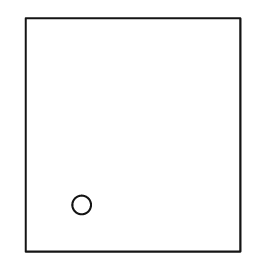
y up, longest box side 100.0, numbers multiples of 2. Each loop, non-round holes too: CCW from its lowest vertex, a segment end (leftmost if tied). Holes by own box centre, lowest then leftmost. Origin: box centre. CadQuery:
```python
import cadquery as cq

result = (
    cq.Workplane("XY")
    .moveTo(-46.0, -50.0)
    .lineTo(46.0, -50.0)
    .lineTo(46.0, 50.0)
    .lineTo(-46.0, 50.0)
    .close()
    .moveTo(-22.0, -30.0)
    .circle(4.0)
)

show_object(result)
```